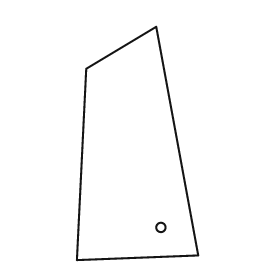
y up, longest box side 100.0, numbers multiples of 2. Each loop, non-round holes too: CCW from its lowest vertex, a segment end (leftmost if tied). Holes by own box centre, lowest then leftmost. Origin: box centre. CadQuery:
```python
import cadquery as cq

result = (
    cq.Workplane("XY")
    .moveTo(-26.0, -50.0)
    .lineTo(26.0, -48.0)
    .lineTo(8.0, 50.0)
    .lineTo(-22.0, 32.0)
    .close()
    .moveTo(10.0, -36.0)
    .circle(2.0)
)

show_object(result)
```